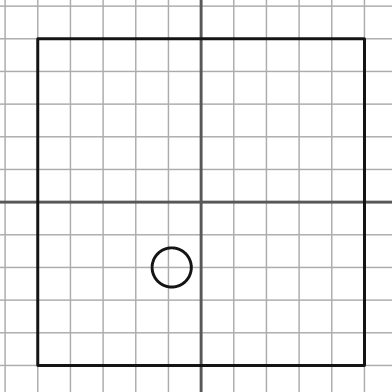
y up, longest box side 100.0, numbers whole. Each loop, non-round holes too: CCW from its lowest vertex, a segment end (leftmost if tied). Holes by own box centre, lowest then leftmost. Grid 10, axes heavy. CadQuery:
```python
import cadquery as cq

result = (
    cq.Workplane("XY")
    .moveTo(-50.0, -50.0)
    .lineTo(50.0, -50.0)
    .lineTo(50.0, 50.0)
    .lineTo(-50.0, 50.0)
    .close()
    .moveTo(-9.0, -20.0)
    .circle(6.0)
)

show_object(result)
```